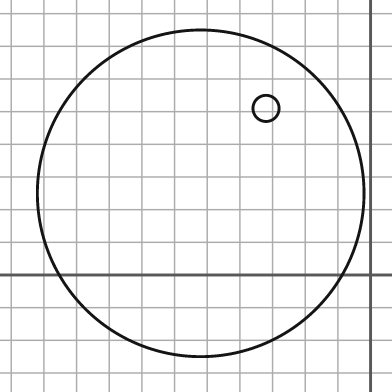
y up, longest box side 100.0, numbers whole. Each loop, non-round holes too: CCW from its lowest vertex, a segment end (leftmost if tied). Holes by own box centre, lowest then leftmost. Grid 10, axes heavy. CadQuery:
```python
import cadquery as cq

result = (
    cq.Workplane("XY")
    .moveTo(-52.0, 25.0)
    .circle(50.0)
    .moveTo(-32.0, 51.0)
    .circle(4.0)
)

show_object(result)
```